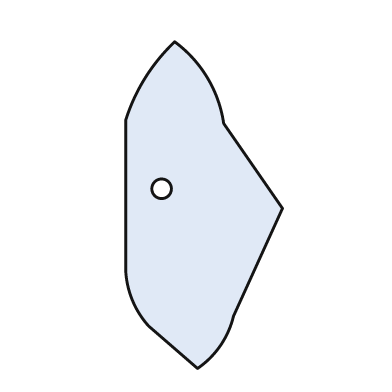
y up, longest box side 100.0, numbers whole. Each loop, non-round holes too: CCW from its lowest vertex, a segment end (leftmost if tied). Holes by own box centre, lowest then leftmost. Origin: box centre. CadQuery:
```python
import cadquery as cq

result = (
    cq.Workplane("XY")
    .moveTo(-2.0, -50.0)
    .threePointArc((5.0, -43.0), (9.0, -34.0))
    .lineTo(24.0, -1.0)
    .lineTo(6.0, 25.0)
    .threePointArc((1.0, 39.0), (-9.0, 50.0))
    .threePointArc((-18.0, 39.0), (-24.0, 26.0))
    .lineTo(-24.0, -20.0)
    .threePointArc((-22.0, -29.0), (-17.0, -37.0))
    .close()
    .moveTo(-13.0, 5.0)
    .circle(3.0)
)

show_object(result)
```